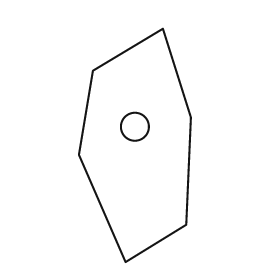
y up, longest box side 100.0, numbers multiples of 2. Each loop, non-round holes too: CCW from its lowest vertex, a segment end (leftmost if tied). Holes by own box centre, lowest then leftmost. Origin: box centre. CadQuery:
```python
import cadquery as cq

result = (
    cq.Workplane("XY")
    .moveTo(-4.0, -50.0)
    .lineTo(22.0, -34.0)
    .lineTo(24.0, 12.0)
    .lineTo(12.0, 50.0)
    .lineTo(-18.0, 32.0)
    .lineTo(-24.0, -4.0)
    .close()
    .moveTo(0.0, 8.0)
    .circle(6.0)
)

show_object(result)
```